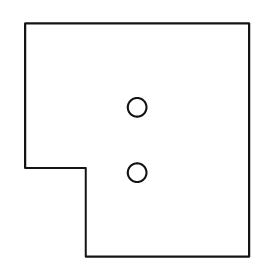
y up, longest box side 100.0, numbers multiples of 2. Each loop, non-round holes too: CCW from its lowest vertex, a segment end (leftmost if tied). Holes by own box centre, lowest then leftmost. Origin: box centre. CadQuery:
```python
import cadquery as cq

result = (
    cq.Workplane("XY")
    .moveTo(-22.0, -50.0)
    .lineTo(48.0, -50.0)
    .lineTo(48.0, 50.0)
    .lineTo(-48.0, 50.0)
    .lineTo(-48.0, -12.0)
    .lineTo(-22.0, -12.0)
    .close()
    .moveTo(0.0, -14.0)
    .circle(4.0)
    .moveTo(0.0, 14.0)
    .circle(4.0)
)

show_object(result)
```